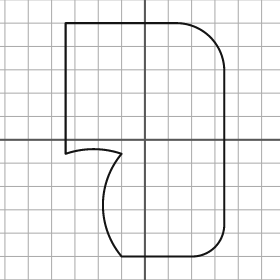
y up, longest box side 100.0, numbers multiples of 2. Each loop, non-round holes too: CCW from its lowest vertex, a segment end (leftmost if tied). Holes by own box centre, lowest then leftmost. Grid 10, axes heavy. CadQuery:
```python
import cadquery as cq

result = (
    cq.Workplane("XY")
    .moveTo(-10.0, -50.0)
    .lineTo(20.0, -50.0)
    .threePointArc((30.0, -46.0), (34.0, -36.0))
    .lineTo(34.0, 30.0)
    .threePointArc((28.0, 44.0), (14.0, 50.0))
    .lineTo(-34.0, 50.0)
    .lineTo(-34.0, -6.0)
    .threePointArc((-22.0, -4.0), (-10.0, -6.0))
    .threePointArc((-18.0, -28.0), (-10.0, -50.0))
    .close()
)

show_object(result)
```